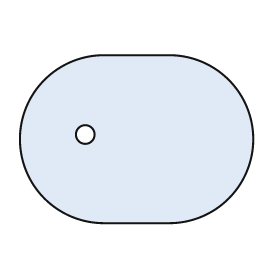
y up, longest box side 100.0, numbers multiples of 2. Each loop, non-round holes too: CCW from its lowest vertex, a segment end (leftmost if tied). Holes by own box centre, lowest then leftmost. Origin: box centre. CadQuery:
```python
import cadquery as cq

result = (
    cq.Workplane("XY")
    .moveTo(-14.0, -36.0)
    .lineTo(14.0, -36.0)
    .threePointArc((50.0, 0.0), (14.0, 36.0))
    .lineTo(-14.0, 36.0)
    .threePointArc((-50.0, 0.0), (-14.0, -36.0))
    .close()
    .moveTo(-22.0, 2.0)
    .circle(4.0)
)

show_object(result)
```